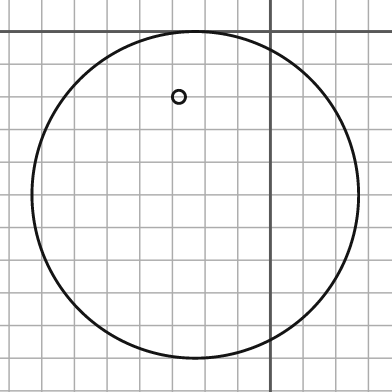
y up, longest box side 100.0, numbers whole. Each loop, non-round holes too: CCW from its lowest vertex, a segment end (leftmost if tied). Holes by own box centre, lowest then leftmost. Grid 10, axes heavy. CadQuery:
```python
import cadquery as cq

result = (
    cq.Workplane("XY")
    .moveTo(-23.0, -50.0)
    .circle(50.0)
    .moveTo(-28.0, -20.0)
    .circle(2.0)
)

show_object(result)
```